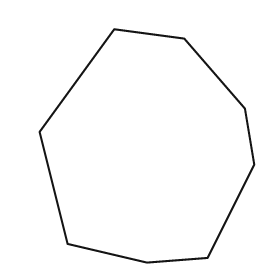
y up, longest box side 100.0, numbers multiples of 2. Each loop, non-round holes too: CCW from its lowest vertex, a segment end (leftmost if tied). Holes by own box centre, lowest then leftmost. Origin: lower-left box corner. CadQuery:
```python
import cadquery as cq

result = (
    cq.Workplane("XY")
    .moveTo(46.0, 0.0)
    .lineTo(72.0, 2.0)
    .lineTo(92.0, 42.0)
    .lineTo(88.0, 66.0)
    .lineTo(62.0, 96.0)
    .lineTo(32.0, 100.0)
    .lineTo(0.0, 56.0)
    .lineTo(12.0, 8.0)
    .close()
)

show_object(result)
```